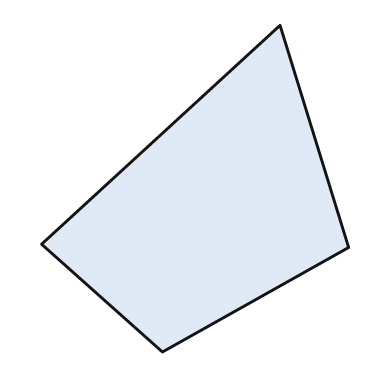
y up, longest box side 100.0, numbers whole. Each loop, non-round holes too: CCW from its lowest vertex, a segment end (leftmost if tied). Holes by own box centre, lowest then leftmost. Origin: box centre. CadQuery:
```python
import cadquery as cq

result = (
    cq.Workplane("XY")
    .moveTo(-10.0, -50.0)
    .lineTo(47.0, -18.0)
    .lineTo(26.0, 50.0)
    .lineTo(-47.0, -17.0)
    .close()
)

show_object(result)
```